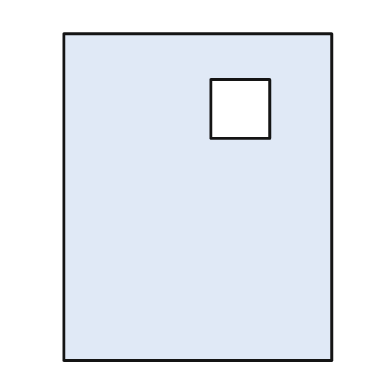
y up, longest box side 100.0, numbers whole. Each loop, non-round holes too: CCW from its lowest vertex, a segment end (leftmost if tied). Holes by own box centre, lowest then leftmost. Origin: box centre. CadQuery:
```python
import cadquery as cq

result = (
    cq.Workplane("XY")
    .moveTo(-41.0, -50.0)
    .lineTo(41.0, -50.0)
    .lineTo(41.0, 50.0)
    .lineTo(-41.0, 50.0)
    .close()
    .moveTo(4.0, 18.0)
    .lineTo(22.0, 18.0)
    .lineTo(22.0, 36.0)
    .lineTo(4.0, 36.0)
    .close()
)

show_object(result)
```